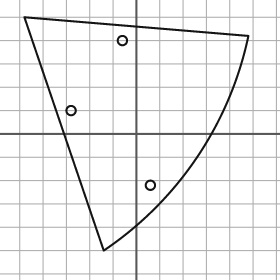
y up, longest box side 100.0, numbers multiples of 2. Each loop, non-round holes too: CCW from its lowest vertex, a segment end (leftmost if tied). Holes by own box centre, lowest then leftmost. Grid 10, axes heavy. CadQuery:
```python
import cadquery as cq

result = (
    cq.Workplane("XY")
    .moveTo(-14.0, -50.0)
    .threePointArc((26.0, -10.0), (48.0, 42.0))
    .lineTo(-48.0, 50.0)
    .close()
    .moveTo(6.0, -22.0)
    .circle(2.0)
    .moveTo(-28.0, 10.0)
    .circle(2.0)
    .moveTo(-6.0, 40.0)
    .circle(2.0)
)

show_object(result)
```